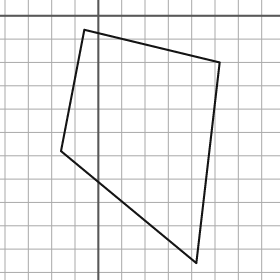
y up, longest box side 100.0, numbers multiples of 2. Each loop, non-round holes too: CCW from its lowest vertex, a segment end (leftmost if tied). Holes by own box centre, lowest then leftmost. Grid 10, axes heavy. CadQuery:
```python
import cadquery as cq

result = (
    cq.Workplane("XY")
    .moveTo(42.0, -106.0)
    .lineTo(52.0, -20.0)
    .lineTo(-6.0, -6.0)
    .lineTo(-16.0, -58.0)
    .close()
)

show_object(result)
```